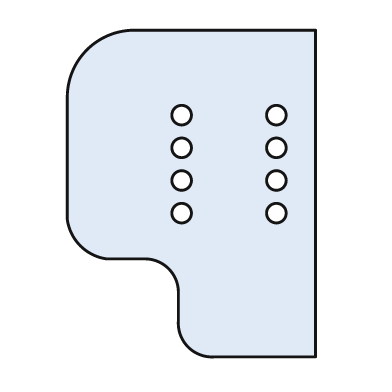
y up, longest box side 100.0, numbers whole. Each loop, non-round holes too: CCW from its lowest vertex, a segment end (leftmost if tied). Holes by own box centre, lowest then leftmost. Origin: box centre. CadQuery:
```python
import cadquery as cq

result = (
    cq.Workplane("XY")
    .moveTo(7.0, -50.0)
    .lineTo(38.0, -50.0)
    .lineTo(38.0, 50.0)
    .lineTo(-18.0, 50.0)
    .threePointArc((-32.0, 44.0), (-38.0, 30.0))
    .lineTo(-38.0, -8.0)
    .threePointArc((-34.0, -16.0), (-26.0, -20.0))
    .lineTo(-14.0, -20.0)
    .threePointArc((-7.0, -23.0), (-4.0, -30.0))
    .lineTo(-4.0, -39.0)
    .threePointArc((-1.0, -47.0), (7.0, -50.0))
    .close()
    .moveTo(-3.0, -6.0)
    .circle(3.0)
    .moveTo(26.0, -6.0)
    .circle(3.0)
    .moveTo(-3.0, 4.0)
    .circle(3.0)
    .moveTo(26.0, 4.0)
    .circle(3.0)
    .moveTo(-3.0, 14.0)
    .circle(3.0)
    .moveTo(26.0, 14.0)
    .circle(3.0)
    .moveTo(-3.0, 24.0)
    .circle(3.0)
    .moveTo(26.0, 24.0)
    .circle(3.0)
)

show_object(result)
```